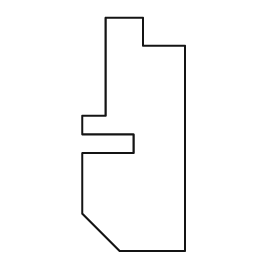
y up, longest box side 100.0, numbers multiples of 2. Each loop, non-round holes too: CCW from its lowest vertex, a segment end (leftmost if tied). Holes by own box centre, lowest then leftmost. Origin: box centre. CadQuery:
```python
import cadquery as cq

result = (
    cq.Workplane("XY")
    .moveTo(-6.0, -50.0)
    .lineTo(22.0, -50.0)
    .lineTo(22.0, 38.0)
    .lineTo(4.0, 38.0)
    .lineTo(4.0, 50.0)
    .lineTo(-12.0, 50.0)
    .lineTo(-12.0, 8.0)
    .lineTo(-22.0, 8.0)
    .lineTo(-22.0, 0.0)
    .lineTo(0.0, 0.0)
    .lineTo(0.0, -8.0)
    .lineTo(-22.0, -8.0)
    .lineTo(-22.0, -34.0)
    .close()
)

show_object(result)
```